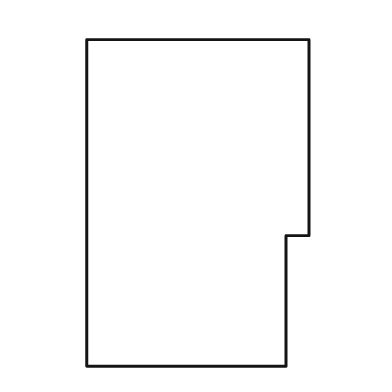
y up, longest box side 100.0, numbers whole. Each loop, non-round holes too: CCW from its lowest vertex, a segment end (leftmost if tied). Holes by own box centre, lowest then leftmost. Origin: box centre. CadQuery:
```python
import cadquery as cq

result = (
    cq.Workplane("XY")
    .moveTo(-34.0, -50.0)
    .lineTo(27.0, -50.0)
    .lineTo(27.0, -10.0)
    .lineTo(34.0, -10.0)
    .lineTo(34.0, 50.0)
    .lineTo(-34.0, 50.0)
    .close()
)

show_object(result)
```